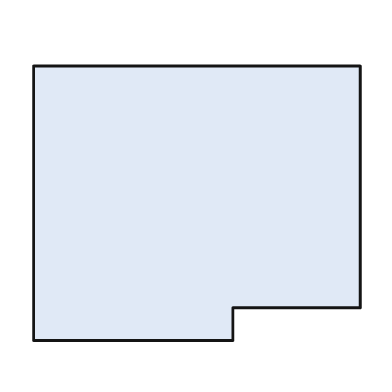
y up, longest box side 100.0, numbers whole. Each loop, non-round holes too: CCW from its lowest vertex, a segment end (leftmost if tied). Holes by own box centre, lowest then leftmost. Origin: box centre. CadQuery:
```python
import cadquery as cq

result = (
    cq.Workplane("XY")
    .moveTo(-50.0, -42.0)
    .lineTo(11.0, -42.0)
    .lineTo(11.0, -32.0)
    .lineTo(50.0, -32.0)
    .lineTo(50.0, 42.0)
    .lineTo(-50.0, 42.0)
    .close()
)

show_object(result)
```